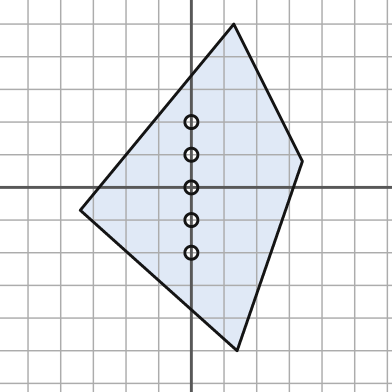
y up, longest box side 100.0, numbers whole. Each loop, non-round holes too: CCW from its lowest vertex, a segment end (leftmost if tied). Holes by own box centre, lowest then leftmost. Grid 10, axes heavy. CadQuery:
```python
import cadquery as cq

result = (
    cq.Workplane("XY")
    .moveTo(14.0, -50.0)
    .lineTo(34.0, 8.0)
    .lineTo(13.0, 50.0)
    .lineTo(-34.0, -7.0)
    .close()
    .moveTo(0.0, -20.0)
    .circle(2.0)
    .moveTo(0.0, -10.0)
    .circle(2.0)
    .moveTo(0.0, 0.0)
    .circle(2.0)
    .moveTo(0.0, 10.0)
    .circle(2.0)
    .moveTo(0.0, 20.0)
    .circle(2.0)
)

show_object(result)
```